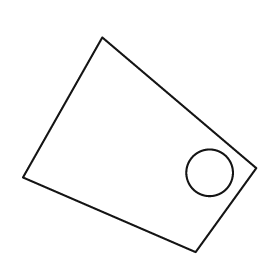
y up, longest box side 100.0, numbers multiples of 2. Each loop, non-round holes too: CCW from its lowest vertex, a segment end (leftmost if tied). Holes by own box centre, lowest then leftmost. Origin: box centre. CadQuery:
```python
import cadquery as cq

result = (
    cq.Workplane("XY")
    .moveTo(24.0, -46.0)
    .lineTo(50.0, -10.0)
    .lineTo(-16.0, 46.0)
    .lineTo(-50.0, -14.0)
    .close()
    .moveTo(30.0, -12.0)
    .circle(10.0)
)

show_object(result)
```